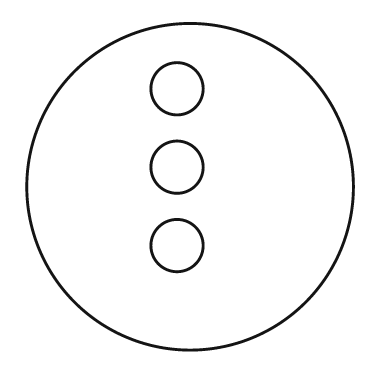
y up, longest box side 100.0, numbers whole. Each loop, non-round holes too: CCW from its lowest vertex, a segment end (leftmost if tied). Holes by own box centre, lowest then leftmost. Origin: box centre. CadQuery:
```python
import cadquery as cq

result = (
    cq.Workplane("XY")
    .moveTo(0.0, 0.0)
    .circle(50.0)
    .moveTo(-4.0, -18.0)
    .circle(8.0)
    .moveTo(-4.0, 6.0)
    .circle(8.0)
    .moveTo(-4.0, 30.0)
    .circle(8.0)
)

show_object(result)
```